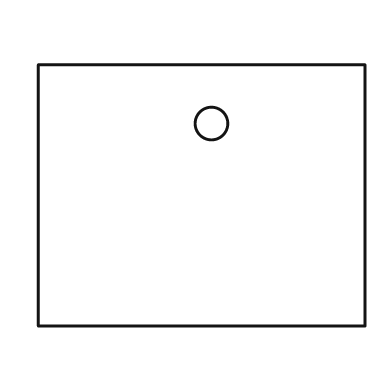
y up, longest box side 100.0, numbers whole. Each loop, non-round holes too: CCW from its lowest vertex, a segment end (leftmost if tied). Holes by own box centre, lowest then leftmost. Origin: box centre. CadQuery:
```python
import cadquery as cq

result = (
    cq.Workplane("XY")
    .moveTo(-50.0, -40.0)
    .lineTo(50.0, -40.0)
    .lineTo(50.0, 40.0)
    .lineTo(-50.0, 40.0)
    .close()
    .moveTo(3.0, 22.0)
    .circle(5.0)
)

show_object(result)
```